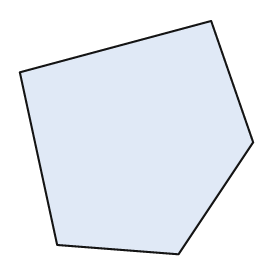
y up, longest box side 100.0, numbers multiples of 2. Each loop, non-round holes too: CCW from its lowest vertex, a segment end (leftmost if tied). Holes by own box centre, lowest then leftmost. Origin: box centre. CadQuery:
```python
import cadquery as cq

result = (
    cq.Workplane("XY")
    .moveTo(18.0, -50.0)
    .lineTo(50.0, -2.0)
    .lineTo(32.0, 50.0)
    .lineTo(-50.0, 28.0)
    .lineTo(-34.0, -46.0)
    .close()
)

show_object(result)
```